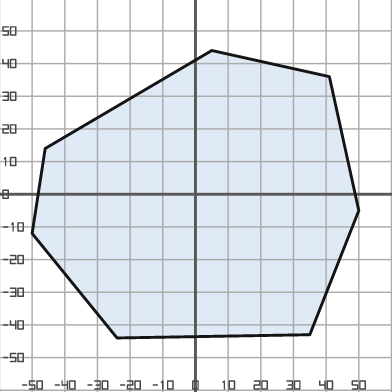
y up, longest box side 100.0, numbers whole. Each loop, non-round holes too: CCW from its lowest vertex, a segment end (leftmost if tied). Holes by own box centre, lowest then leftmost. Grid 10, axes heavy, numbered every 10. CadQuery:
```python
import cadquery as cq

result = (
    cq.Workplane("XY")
    .moveTo(-24.0, -44.0)
    .lineTo(35.0, -43.0)
    .lineTo(50.0, -5.0)
    .lineTo(41.0, 36.0)
    .lineTo(5.0, 44.0)
    .lineTo(-46.0, 14.0)
    .lineTo(-50.0, -12.0)
    .close()
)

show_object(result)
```